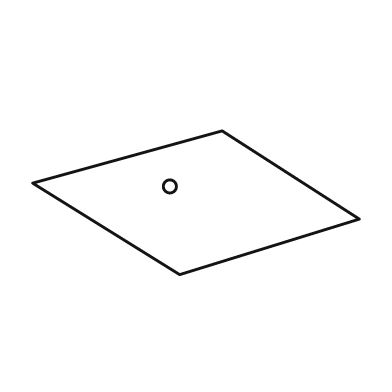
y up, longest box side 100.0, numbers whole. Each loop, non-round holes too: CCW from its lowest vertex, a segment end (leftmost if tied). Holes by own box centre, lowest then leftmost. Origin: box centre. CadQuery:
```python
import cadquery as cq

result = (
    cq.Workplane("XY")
    .moveTo(-5.0, -22.0)
    .lineTo(50.0, -5.0)
    .lineTo(8.0, 22.0)
    .lineTo(-50.0, 6.0)
    .close()
    .moveTo(-8.0, 5.0)
    .circle(2.0)
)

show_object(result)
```